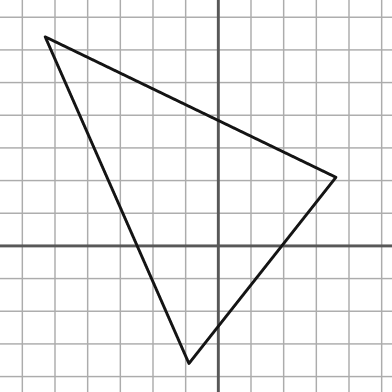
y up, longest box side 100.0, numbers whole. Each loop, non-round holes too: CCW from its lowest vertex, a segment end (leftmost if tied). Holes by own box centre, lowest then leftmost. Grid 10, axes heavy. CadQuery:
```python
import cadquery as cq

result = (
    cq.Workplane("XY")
    .moveTo(-9.0, -36.0)
    .lineTo(36.0, 21.0)
    .lineTo(-53.0, 64.0)
    .close()
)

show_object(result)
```